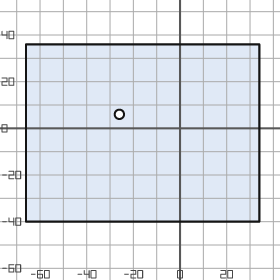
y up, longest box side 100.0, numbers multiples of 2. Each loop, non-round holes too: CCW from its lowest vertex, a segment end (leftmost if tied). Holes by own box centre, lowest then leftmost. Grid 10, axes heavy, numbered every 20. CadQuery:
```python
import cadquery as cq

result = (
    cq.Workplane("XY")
    .moveTo(-66.0, -40.0)
    .lineTo(34.0, -40.0)
    .lineTo(34.0, 36.0)
    .lineTo(-66.0, 36.0)
    .close()
    .moveTo(-26.0, 6.0)
    .circle(2.0)
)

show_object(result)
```